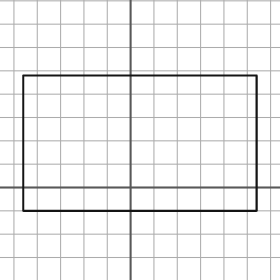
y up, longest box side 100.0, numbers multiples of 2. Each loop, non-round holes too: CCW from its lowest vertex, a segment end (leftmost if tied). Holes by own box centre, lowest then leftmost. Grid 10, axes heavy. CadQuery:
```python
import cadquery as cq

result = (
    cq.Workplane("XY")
    .moveTo(-46.0, -10.0)
    .lineTo(54.0, -10.0)
    .lineTo(54.0, 48.0)
    .lineTo(-46.0, 48.0)
    .close()
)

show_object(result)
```